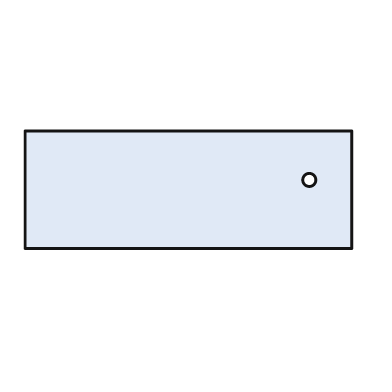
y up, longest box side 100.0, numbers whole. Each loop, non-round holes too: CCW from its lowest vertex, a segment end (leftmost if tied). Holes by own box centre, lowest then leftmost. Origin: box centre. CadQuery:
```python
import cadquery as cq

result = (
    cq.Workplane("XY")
    .moveTo(-50.0, -18.0)
    .lineTo(50.0, -18.0)
    .lineTo(50.0, 18.0)
    .lineTo(-50.0, 18.0)
    .close()
    .moveTo(37.0, 3.0)
    .circle(2.0)
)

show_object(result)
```